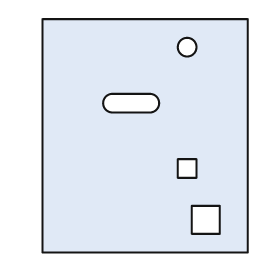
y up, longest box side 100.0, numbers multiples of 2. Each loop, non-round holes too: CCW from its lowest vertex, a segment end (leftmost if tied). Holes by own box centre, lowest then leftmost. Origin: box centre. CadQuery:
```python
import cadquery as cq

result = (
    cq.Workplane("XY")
    .moveTo(-44.0, -50.0)
    .lineTo(44.0, -50.0)
    .lineTo(44.0, 50.0)
    .lineTo(-44.0, 50.0)
    .close()
    .moveTo(20.0, -42.0)
    .lineTo(32.0, -42.0)
    .lineTo(32.0, -30.0)
    .lineTo(20.0, -30.0)
    .close()
    .moveTo(14.0, -18.0)
    .lineTo(22.0, -18.0)
    .lineTo(22.0, -10.0)
    .lineTo(14.0, -10.0)
    .close()
    .moveTo(-14.0, 10.0)
    .lineTo(2.0, 10.0)
    .threePointArc((6.0, 14.0), (2.0, 18.0))
    .lineTo(-14.0, 18.0)
    .threePointArc((-18.0, 14.0), (-14.0, 10.0))
    .close()
    .moveTo(18.0, 38.0)
    .circle(4.0)
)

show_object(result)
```